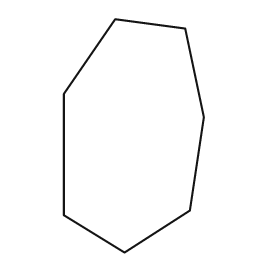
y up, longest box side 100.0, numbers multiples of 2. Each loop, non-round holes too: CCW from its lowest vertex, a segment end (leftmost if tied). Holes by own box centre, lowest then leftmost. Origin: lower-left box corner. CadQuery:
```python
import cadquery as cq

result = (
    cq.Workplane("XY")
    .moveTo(26.0, 0.0)
    .lineTo(54.0, 18.0)
    .lineTo(60.0, 58.0)
    .lineTo(52.0, 96.0)
    .lineTo(22.0, 100.0)
    .lineTo(0.0, 68.0)
    .lineTo(0.0, 16.0)
    .close()
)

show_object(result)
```